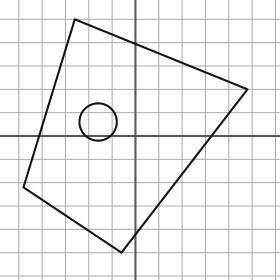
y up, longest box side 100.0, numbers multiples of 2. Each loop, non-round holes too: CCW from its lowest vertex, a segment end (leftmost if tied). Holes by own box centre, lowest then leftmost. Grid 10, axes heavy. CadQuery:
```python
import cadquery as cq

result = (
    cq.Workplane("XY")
    .moveTo(-6.0, -50.0)
    .lineTo(48.0, 20.0)
    .lineTo(-26.0, 50.0)
    .lineTo(-48.0, -22.0)
    .close()
    .moveTo(-16.0, 6.0)
    .circle(8.0)
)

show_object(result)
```